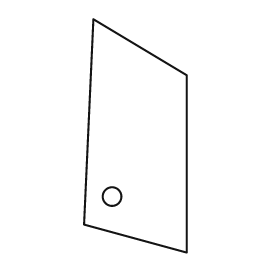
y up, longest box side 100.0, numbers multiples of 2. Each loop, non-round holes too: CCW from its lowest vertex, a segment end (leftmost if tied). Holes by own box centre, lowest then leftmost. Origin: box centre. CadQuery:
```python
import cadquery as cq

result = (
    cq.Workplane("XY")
    .moveTo(22.0, -50.0)
    .lineTo(22.0, 26.0)
    .lineTo(-18.0, 50.0)
    .lineTo(-22.0, -38.0)
    .close()
    .moveTo(-10.0, -26.0)
    .circle(4.0)
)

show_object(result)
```